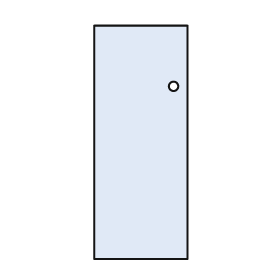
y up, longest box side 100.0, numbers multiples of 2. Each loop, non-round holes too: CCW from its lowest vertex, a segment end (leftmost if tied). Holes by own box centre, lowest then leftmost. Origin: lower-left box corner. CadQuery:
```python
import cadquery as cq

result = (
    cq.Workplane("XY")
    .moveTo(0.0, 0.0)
    .lineTo(40.0, 0.0)
    .lineTo(40.0, 100.0)
    .lineTo(0.0, 100.0)
    .close()
    .moveTo(34.0, 74.0)
    .circle(2.0)
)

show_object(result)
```